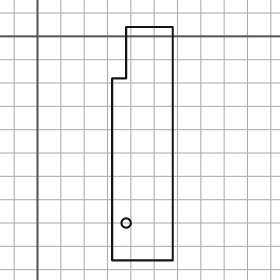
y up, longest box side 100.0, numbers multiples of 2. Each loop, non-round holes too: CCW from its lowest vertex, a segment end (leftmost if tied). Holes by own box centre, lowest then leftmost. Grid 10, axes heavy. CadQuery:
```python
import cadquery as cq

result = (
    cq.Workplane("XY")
    .moveTo(32.0, -96.0)
    .lineTo(58.0, -96.0)
    .lineTo(58.0, 4.0)
    .lineTo(38.0, 4.0)
    .lineTo(38.0, -18.0)
    .lineTo(32.0, -18.0)
    .close()
    .moveTo(38.0, -80.0)
    .circle(2.0)
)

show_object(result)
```